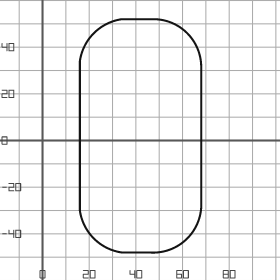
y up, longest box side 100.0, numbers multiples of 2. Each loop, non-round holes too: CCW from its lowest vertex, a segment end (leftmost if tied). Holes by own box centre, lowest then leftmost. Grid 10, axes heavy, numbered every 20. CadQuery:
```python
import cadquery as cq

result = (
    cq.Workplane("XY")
    .moveTo(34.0, -48.0)
    .lineTo(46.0, -48.0)
    .threePointArc((62.0, -42.0), (68.0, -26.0))
    .lineTo(68.0, 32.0)
    .threePointArc((62.0, 46.0), (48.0, 52.0))
    .lineTo(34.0, 52.0)
    .threePointArc((22.0, 46.0), (16.0, 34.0))
    .lineTo(16.0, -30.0)
    .threePointArc((22.0, -42.0), (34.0, -48.0))
    .close()
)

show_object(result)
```